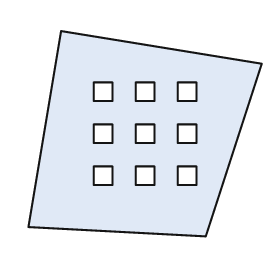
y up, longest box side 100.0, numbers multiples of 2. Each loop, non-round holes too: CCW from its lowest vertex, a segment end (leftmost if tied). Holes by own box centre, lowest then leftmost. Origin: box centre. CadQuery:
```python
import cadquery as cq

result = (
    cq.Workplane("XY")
    .moveTo(26.0, -44.0)
    .lineTo(50.0, 30.0)
    .lineTo(-36.0, 44.0)
    .lineTo(-50.0, -40.0)
    .close()
    .moveTo(-22.0, -22.0)
    .lineTo(-14.0, -22.0)
    .lineTo(-14.0, -14.0)
    .lineTo(-22.0, -14.0)
    .close()
    .moveTo(-4.0, -22.0)
    .lineTo(4.0, -22.0)
    .lineTo(4.0, -14.0)
    .lineTo(-4.0, -14.0)
    .close()
    .moveTo(14.0, -22.0)
    .lineTo(22.0, -22.0)
    .lineTo(22.0, -14.0)
    .lineTo(14.0, -14.0)
    .close()
    .moveTo(-22.0, -4.0)
    .lineTo(-14.0, -4.0)
    .lineTo(-14.0, 4.0)
    .lineTo(-22.0, 4.0)
    .close()
    .moveTo(-4.0, -4.0)
    .lineTo(4.0, -4.0)
    .lineTo(4.0, 4.0)
    .lineTo(-4.0, 4.0)
    .close()
    .moveTo(14.0, -4.0)
    .lineTo(22.0, -4.0)
    .lineTo(22.0, 4.0)
    .lineTo(14.0, 4.0)
    .close()
    .moveTo(-22.0, 14.0)
    .lineTo(-14.0, 14.0)
    .lineTo(-14.0, 22.0)
    .lineTo(-22.0, 22.0)
    .close()
    .moveTo(-4.0, 14.0)
    .lineTo(4.0, 14.0)
    .lineTo(4.0, 22.0)
    .lineTo(-4.0, 22.0)
    .close()
    .moveTo(14.0, 14.0)
    .lineTo(22.0, 14.0)
    .lineTo(22.0, 22.0)
    .lineTo(14.0, 22.0)
    .close()
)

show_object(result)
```